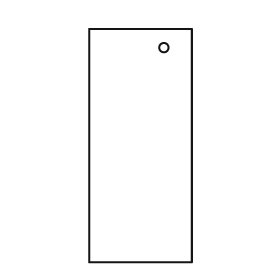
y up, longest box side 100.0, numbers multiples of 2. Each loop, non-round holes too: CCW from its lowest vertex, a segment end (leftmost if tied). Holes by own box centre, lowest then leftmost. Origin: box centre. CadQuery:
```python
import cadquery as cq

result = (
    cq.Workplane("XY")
    .moveTo(-22.0, -50.0)
    .lineTo(22.0, -50.0)
    .lineTo(22.0, 50.0)
    .lineTo(-22.0, 50.0)
    .close()
    .moveTo(10.0, 42.0)
    .circle(2.0)
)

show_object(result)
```